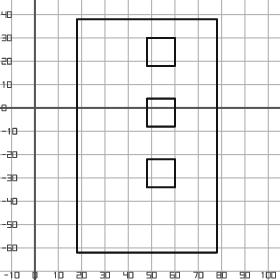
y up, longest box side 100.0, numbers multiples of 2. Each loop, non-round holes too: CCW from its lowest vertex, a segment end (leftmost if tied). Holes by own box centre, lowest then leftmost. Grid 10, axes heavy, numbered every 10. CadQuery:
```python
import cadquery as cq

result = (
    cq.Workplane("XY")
    .moveTo(18.0, -62.0)
    .lineTo(78.0, -62.0)
    .lineTo(78.0, 38.0)
    .lineTo(18.0, 38.0)
    .close()
    .moveTo(48.0, -34.0)
    .lineTo(60.0, -34.0)
    .lineTo(60.0, -22.0)
    .lineTo(48.0, -22.0)
    .close()
    .moveTo(48.0, -8.0)
    .lineTo(60.0, -8.0)
    .lineTo(60.0, 4.0)
    .lineTo(48.0, 4.0)
    .close()
    .moveTo(48.0, 18.0)
    .lineTo(60.0, 18.0)
    .lineTo(60.0, 30.0)
    .lineTo(48.0, 30.0)
    .close()
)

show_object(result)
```